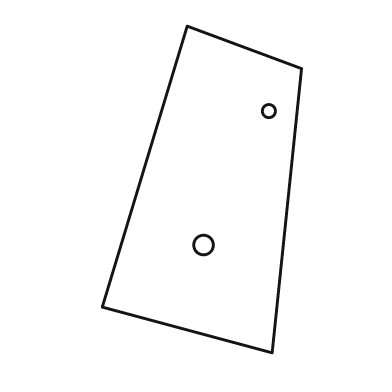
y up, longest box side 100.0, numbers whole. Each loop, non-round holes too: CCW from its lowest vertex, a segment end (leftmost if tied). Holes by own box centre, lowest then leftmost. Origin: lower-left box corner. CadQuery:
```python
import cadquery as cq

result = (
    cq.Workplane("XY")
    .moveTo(52.0, 0.0)
    .lineTo(61.0, 87.0)
    .lineTo(26.0, 100.0)
    .lineTo(0.0, 14.0)
    .close()
    .moveTo(31.0, 33.0)
    .circle(3.0)
    .moveTo(51.0, 74.0)
    .circle(2.0)
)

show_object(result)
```